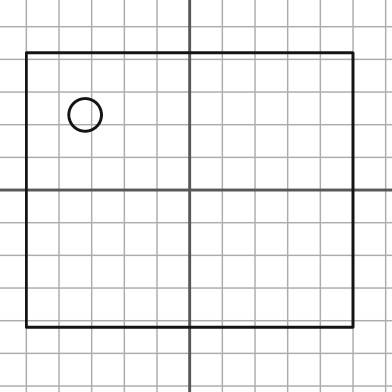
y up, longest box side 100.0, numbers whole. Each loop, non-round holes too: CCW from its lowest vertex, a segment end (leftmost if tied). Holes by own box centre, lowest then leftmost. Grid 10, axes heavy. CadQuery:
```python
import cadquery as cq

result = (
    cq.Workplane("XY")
    .moveTo(-50.0, -42.0)
    .lineTo(50.0, -42.0)
    .lineTo(50.0, 42.0)
    .lineTo(-50.0, 42.0)
    .close()
    .moveTo(-32.0, 23.0)
    .circle(5.0)
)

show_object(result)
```